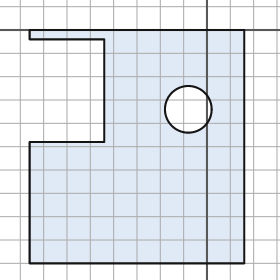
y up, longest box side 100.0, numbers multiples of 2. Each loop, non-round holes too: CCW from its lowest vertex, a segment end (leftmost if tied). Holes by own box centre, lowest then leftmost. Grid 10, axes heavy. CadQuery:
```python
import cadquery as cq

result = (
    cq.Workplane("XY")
    .moveTo(-76.0, -100.0)
    .lineTo(16.0, -100.0)
    .lineTo(16.0, 0.0)
    .lineTo(-76.0, 0.0)
    .lineTo(-76.0, -4.0)
    .lineTo(-44.0, -4.0)
    .lineTo(-44.0, -48.0)
    .lineTo(-76.0, -48.0)
    .close()
    .moveTo(-8.0, -34.0)
    .circle(10.0)
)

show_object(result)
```